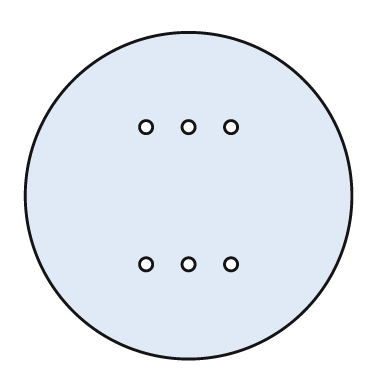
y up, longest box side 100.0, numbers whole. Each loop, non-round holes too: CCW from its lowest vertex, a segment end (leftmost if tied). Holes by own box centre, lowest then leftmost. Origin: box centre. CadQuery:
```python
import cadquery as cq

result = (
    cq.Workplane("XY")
    .moveTo(0.0, 0.0)
    .circle(50.0)
    .moveTo(-13.0, -21.0)
    .circle(2.0)
    .moveTo(0.0, -21.0)
    .circle(2.0)
    .moveTo(13.0, -21.0)
    .circle(2.0)
    .moveTo(-13.0, 21.0)
    .circle(2.0)
    .moveTo(0.0, 21.0)
    .circle(2.0)
    .moveTo(13.0, 21.0)
    .circle(2.0)
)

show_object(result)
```